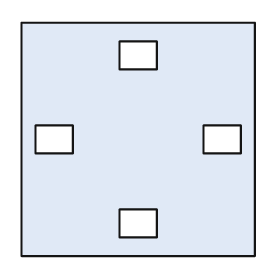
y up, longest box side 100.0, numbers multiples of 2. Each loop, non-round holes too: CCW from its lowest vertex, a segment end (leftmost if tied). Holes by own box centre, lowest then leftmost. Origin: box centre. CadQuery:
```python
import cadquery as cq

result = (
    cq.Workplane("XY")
    .moveTo(-50.0, -50.0)
    .lineTo(50.0, -50.0)
    .lineTo(50.0, 50.0)
    .lineTo(-50.0, 50.0)
    .close()
    .moveTo(-8.0, -42.0)
    .lineTo(8.0, -42.0)
    .lineTo(8.0, -30.0)
    .lineTo(-8.0, -30.0)
    .close()
    .moveTo(-44.0, -6.0)
    .lineTo(-28.0, -6.0)
    .lineTo(-28.0, 6.0)
    .lineTo(-44.0, 6.0)
    .close()
    .moveTo(28.0, -6.0)
    .lineTo(44.0, -6.0)
    .lineTo(44.0, 6.0)
    .lineTo(28.0, 6.0)
    .close()
    .moveTo(-8.0, 30.0)
    .lineTo(8.0, 30.0)
    .lineTo(8.0, 42.0)
    .lineTo(-8.0, 42.0)
    .close()
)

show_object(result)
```